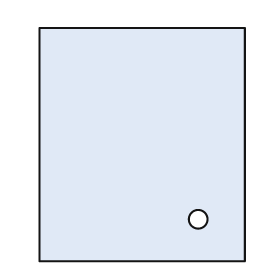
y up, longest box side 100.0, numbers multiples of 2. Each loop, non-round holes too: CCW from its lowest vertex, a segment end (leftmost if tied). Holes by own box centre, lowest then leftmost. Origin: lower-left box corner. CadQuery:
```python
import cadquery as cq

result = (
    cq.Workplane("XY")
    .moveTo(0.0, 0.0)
    .lineTo(88.0, 0.0)
    .lineTo(88.0, 100.0)
    .lineTo(0.0, 100.0)
    .close()
    .moveTo(68.0, 18.0)
    .circle(4.0)
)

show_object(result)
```